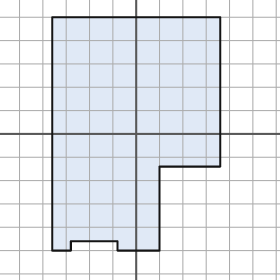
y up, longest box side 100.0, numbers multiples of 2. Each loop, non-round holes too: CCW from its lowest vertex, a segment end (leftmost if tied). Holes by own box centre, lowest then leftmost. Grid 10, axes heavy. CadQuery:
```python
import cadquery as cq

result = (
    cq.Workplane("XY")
    .moveTo(-36.0, -50.0)
    .lineTo(-28.0, -50.0)
    .lineTo(-28.0, -46.0)
    .lineTo(-8.0, -46.0)
    .lineTo(-8.0, -50.0)
    .lineTo(10.0, -50.0)
    .lineTo(10.0, -14.0)
    .lineTo(36.0, -14.0)
    .lineTo(36.0, 50.0)
    .lineTo(-36.0, 50.0)
    .close()
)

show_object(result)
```